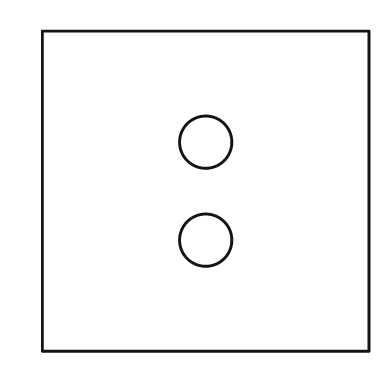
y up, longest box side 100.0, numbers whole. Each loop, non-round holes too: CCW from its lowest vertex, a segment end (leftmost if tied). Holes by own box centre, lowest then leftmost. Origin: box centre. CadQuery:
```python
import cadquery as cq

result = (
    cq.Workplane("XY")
    .moveTo(-50.0, -49.0)
    .lineTo(50.0, -49.0)
    .lineTo(50.0, 49.0)
    .lineTo(-50.0, 49.0)
    .close()
    .moveTo(0.0, -15.0)
    .circle(8.0)
    .moveTo(0.0, 15.0)
    .circle(8.0)
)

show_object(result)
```